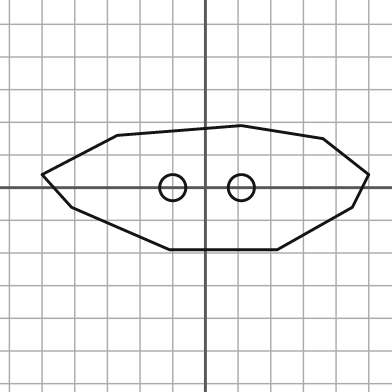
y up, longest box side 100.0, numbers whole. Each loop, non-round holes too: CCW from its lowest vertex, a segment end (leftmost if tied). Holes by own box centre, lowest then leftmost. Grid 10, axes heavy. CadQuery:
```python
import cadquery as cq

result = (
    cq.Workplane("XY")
    .moveTo(-11.0, -19.0)
    .lineTo(22.0, -19.0)
    .lineTo(45.0, -6.0)
    .lineTo(50.0, 4.0)
    .lineTo(36.0, 15.0)
    .lineTo(11.0, 19.0)
    .lineTo(-27.0, 16.0)
    .lineTo(-50.0, 4.0)
    .lineTo(-41.0, -6.0)
    .close()
    .moveTo(-10.0, 0.0)
    .circle(4.0)
    .moveTo(11.0, 0.0)
    .circle(4.0)
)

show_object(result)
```